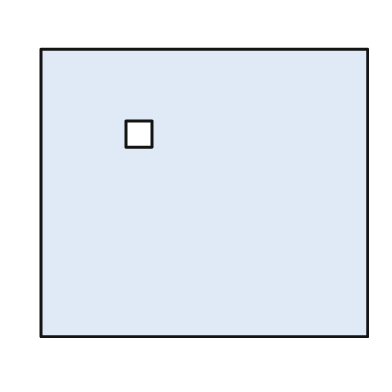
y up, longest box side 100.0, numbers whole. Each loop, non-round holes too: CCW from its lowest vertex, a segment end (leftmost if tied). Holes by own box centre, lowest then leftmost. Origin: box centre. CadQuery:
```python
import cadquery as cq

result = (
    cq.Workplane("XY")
    .moveTo(-50.0, -44.0)
    .lineTo(50.0, -44.0)
    .lineTo(50.0, 44.0)
    .lineTo(-50.0, 44.0)
    .close()
    .moveTo(-24.0, 14.0)
    .lineTo(-16.0, 14.0)
    .lineTo(-16.0, 22.0)
    .lineTo(-24.0, 22.0)
    .close()
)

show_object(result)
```